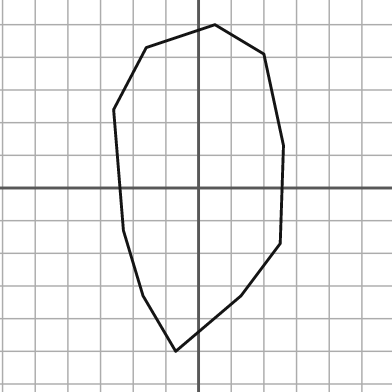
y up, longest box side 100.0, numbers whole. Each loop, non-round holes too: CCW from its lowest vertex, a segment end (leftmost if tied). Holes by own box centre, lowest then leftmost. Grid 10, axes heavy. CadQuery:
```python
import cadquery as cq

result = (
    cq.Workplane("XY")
    .moveTo(-7.0, -50.0)
    .lineTo(13.0, -33.0)
    .lineTo(25.0, -17.0)
    .lineTo(26.0, 13.0)
    .lineTo(20.0, 41.0)
    .lineTo(5.0, 50.0)
    .lineTo(-16.0, 43.0)
    .lineTo(-26.0, 24.0)
    .lineTo(-23.0, -13.0)
    .lineTo(-17.0, -33.0)
    .close()
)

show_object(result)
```